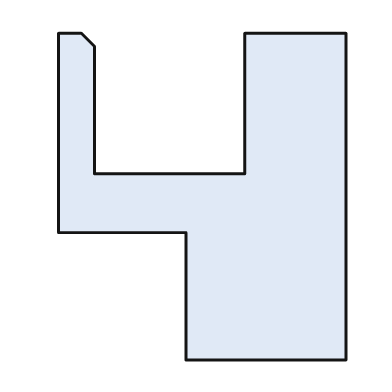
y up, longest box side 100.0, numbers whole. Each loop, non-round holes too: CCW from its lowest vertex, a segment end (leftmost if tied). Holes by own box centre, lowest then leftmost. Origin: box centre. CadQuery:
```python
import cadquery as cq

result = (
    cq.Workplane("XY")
    .moveTo(-5.0, -50.0)
    .lineTo(44.0, -50.0)
    .lineTo(44.0, 50.0)
    .lineTo(13.0, 50.0)
    .lineTo(13.0, 7.0)
    .lineTo(-33.0, 7.0)
    .lineTo(-33.0, 46.0)
    .lineTo(-37.0, 50.0)
    .lineTo(-44.0, 50.0)
    .lineTo(-44.0, -11.0)
    .lineTo(-5.0, -11.0)
    .close()
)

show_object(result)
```